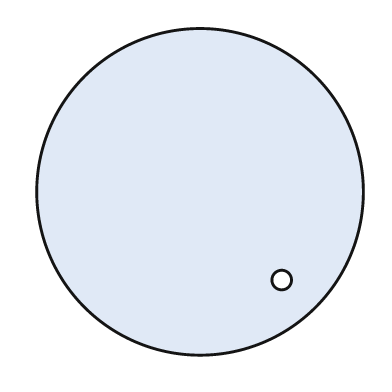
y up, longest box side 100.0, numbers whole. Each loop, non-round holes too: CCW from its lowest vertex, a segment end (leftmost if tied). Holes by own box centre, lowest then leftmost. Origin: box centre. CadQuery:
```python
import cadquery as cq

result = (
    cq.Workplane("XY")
    .moveTo(0.0, 0.0)
    .circle(50.0)
    .moveTo(25.0, -27.0)
    .circle(3.0)
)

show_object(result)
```